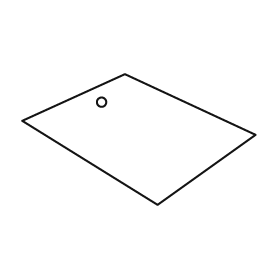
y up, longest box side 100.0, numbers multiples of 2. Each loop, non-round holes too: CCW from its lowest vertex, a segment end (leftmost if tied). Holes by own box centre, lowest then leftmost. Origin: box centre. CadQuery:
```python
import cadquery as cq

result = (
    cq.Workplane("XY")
    .moveTo(8.0, -28.0)
    .lineTo(50.0, 2.0)
    .lineTo(-6.0, 28.0)
    .lineTo(-50.0, 8.0)
    .close()
    .moveTo(-16.0, 16.0)
    .circle(2.0)
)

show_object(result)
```